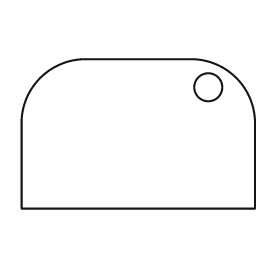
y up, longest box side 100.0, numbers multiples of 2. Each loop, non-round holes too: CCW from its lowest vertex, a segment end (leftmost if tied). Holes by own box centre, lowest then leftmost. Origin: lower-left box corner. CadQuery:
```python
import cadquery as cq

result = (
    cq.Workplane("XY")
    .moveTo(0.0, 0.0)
    .lineTo(100.0, 0.0)
    .lineTo(100.0, 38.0)
    .threePointArc((92.0, 56.0), (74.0, 64.0))
    .lineTo(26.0, 64.0)
    .threePointArc((8.0, 56.0), (0.0, 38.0))
    .close()
    .moveTo(80.0, 52.0)
    .circle(6.0)
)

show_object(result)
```